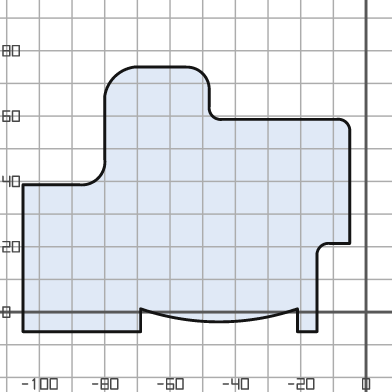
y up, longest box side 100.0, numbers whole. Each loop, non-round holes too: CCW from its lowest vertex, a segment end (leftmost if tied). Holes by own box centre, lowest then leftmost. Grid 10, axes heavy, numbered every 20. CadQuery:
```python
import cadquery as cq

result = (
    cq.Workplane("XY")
    .moveTo(-105.0, -6.0)
    .lineTo(-69.0, -6.0)
    .lineTo(-69.0, 1.0)
    .threePointArc((-45.0, -3.0), (-21.0, 1.0))
    .lineTo(-21.0, -6.0)
    .lineTo(-15.0, -6.0)
    .lineTo(-15.0, 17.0)
    .threePointArc((-14.0, 20.0), (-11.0, 21.0))
    .lineTo(-5.0, 21.0)
    .lineTo(-5.0, 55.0)
    .threePointArc((-6.0, 58.0), (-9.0, 59.0))
    .lineTo(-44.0, 59.0)
    .threePointArc((-47.0, 60.0), (-48.0, 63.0))
    .lineTo(-48.0, 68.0)
    .threePointArc((-50.0, 73.0), (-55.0, 75.0))
    .lineTo(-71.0, 75.0)
    .threePointArc((-77.0, 72.0), (-80.0, 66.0))
    .lineTo(-80.0, 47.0)
    .threePointArc((-82.0, 41.0), (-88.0, 39.0))
    .lineTo(-105.0, 39.0)
    .close()
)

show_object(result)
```